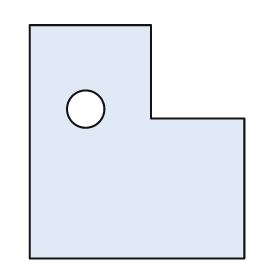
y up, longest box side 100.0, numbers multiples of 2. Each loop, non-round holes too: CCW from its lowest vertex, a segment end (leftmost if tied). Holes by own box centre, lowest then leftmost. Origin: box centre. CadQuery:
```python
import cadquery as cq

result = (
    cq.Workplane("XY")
    .moveTo(-46.0, -50.0)
    .lineTo(46.0, -50.0)
    .lineTo(46.0, 10.0)
    .lineTo(6.0, 10.0)
    .lineTo(6.0, 50.0)
    .lineTo(-46.0, 50.0)
    .close()
    .moveTo(-22.0, 14.0)
    .circle(8.0)
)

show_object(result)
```